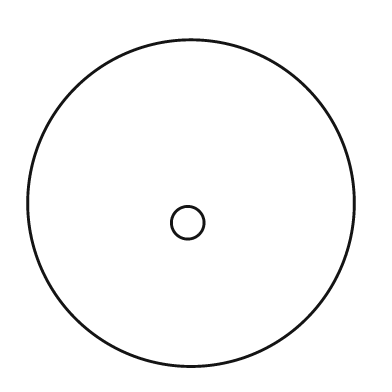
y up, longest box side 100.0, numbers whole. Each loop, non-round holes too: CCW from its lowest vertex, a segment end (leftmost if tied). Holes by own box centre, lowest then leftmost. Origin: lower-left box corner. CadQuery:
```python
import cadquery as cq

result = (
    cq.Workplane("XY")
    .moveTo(50.0, 50.0)
    .circle(50.0)
    .moveTo(49.0, 44.0)
    .circle(5.0)
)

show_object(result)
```